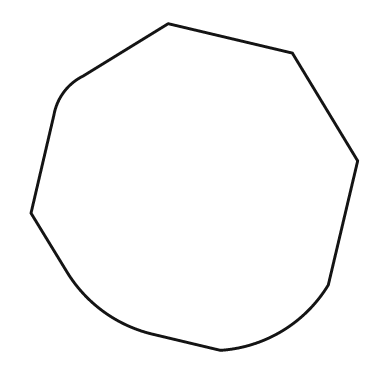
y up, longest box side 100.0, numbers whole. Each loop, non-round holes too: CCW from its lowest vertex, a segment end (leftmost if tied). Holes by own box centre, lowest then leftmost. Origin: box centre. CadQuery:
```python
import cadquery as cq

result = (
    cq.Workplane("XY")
    .moveTo(8.0, -50.0)
    .threePointArc((27.0, -44.0), (41.0, -30.0))
    .lineTo(50.0, 8.0)
    .lineTo(30.0, 41.0)
    .lineTo(-8.0, 50.0)
    .lineTo(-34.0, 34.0)
    .threePointArc((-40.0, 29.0), (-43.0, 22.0))
    .lineTo(-50.0, -8.0)
    .lineTo(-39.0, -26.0)
    .threePointArc((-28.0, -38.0), (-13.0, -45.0))
    .close()
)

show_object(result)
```